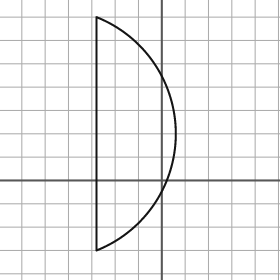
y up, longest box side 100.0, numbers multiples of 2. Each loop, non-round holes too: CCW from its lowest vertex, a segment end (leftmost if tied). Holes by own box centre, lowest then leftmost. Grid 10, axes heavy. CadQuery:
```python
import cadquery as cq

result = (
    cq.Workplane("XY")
    .moveTo(-28.0, -30.0)
    .threePointArc((6.0, 20.0), (-28.0, 70.0))
    .close()
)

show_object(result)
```